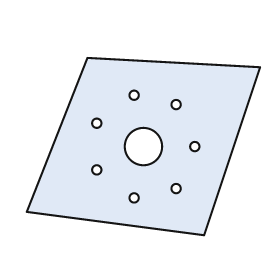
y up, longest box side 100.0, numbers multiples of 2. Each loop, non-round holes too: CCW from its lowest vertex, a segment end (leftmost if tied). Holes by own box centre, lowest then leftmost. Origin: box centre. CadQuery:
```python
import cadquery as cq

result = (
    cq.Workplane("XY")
    .moveTo(26.0, -38.0)
    .lineTo(50.0, 34.0)
    .lineTo(-24.0, 38.0)
    .lineTo(-50.0, -28.0)
    .close()
    .moveTo(-4.0, -22.0)
    .circle(2.0)
    .moveTo(14.0, -18.0)
    .circle(2.0)
    .moveTo(-20.0, -10.0)
    .circle(2.0)
    .moveTo(0.0, 0.0)
    .circle(8.0)
    .moveTo(22.0, 0.0)
    .circle(2.0)
    .moveTo(-20.0, 10.0)
    .circle(2.0)
    .moveTo(14.0, 18.0)
    .circle(2.0)
    .moveTo(-4.0, 22.0)
    .circle(2.0)
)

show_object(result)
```